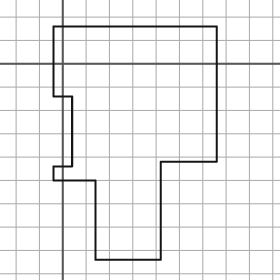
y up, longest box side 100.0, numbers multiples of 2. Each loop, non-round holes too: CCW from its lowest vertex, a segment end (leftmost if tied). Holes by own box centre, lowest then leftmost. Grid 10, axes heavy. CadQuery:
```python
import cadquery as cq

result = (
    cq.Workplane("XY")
    .moveTo(14.0, -84.0)
    .lineTo(42.0, -84.0)
    .lineTo(42.0, -42.0)
    .lineTo(66.0, -42.0)
    .lineTo(66.0, 16.0)
    .lineTo(-4.0, 16.0)
    .lineTo(-4.0, -14.0)
    .lineTo(4.0, -14.0)
    .lineTo(4.0, -44.0)
    .lineTo(-4.0, -44.0)
    .lineTo(-4.0, -50.0)
    .lineTo(14.0, -50.0)
    .close()
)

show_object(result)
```